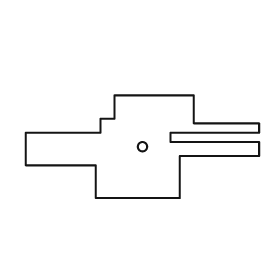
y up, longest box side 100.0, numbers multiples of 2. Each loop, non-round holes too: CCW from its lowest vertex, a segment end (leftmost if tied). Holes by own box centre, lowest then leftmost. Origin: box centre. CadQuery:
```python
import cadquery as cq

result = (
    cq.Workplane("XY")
    .moveTo(-20.0, -22.0)
    .lineTo(16.0, -22.0)
    .lineTo(16.0, -4.0)
    .lineTo(50.0, -4.0)
    .lineTo(50.0, 2.0)
    .lineTo(12.0, 2.0)
    .lineTo(12.0, 6.0)
    .lineTo(50.0, 6.0)
    .lineTo(50.0, 10.0)
    .lineTo(22.0, 10.0)
    .lineTo(22.0, 22.0)
    .lineTo(-12.0, 22.0)
    .lineTo(-12.0, 12.0)
    .lineTo(-18.0, 12.0)
    .lineTo(-18.0, 6.0)
    .lineTo(-50.0, 6.0)
    .lineTo(-50.0, -8.0)
    .lineTo(-20.0, -8.0)
    .close()
    .moveTo(0.0, 0.0)
    .circle(2.0)
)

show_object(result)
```